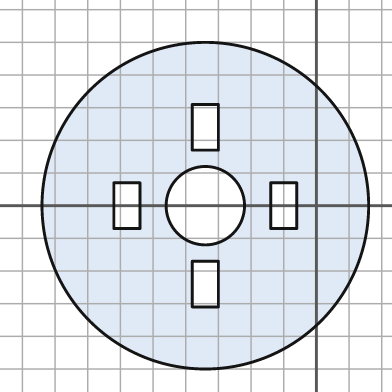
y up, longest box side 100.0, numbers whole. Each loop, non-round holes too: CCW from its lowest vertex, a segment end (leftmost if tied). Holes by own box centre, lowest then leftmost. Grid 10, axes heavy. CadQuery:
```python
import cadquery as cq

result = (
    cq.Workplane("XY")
    .moveTo(-34.0, 0.0)
    .circle(50.0)
    .moveTo(-38.0, -31.0)
    .lineTo(-30.0, -31.0)
    .lineTo(-30.0, -17.0)
    .lineTo(-38.0, -17.0)
    .close()
    .moveTo(-62.0, -7.0)
    .lineTo(-54.0, -7.0)
    .lineTo(-54.0, 7.0)
    .lineTo(-62.0, 7.0)
    .close()
    .moveTo(-34.0, 0.0)
    .circle(12.0)
    .moveTo(-14.0, -7.0)
    .lineTo(-6.0, -7.0)
    .lineTo(-6.0, 7.0)
    .lineTo(-14.0, 7.0)
    .close()
    .moveTo(-38.0, 17.0)
    .lineTo(-30.0, 17.0)
    .lineTo(-30.0, 31.0)
    .lineTo(-38.0, 31.0)
    .close()
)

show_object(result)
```